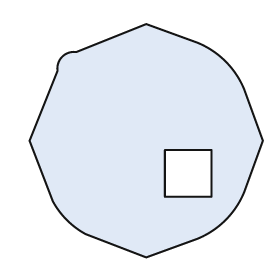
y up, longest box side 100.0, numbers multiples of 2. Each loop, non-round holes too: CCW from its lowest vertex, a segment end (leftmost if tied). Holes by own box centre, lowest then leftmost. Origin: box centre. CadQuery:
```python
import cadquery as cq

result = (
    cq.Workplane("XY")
    .moveTo(0.0, -50.0)
    .lineTo(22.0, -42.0)
    .threePointArc((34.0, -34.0), (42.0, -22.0))
    .lineTo(50.0, 0.0)
    .lineTo(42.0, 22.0)
    .threePointArc((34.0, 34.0), (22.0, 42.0))
    .lineTo(0.0, 50.0)
    .lineTo(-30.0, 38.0)
    .threePointArc((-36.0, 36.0), (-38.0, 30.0))
    .lineTo(-50.0, 0.0)
    .lineTo(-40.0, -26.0)
    .threePointArc((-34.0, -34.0), (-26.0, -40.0))
    .close()
    .moveTo(8.0, -24.0)
    .lineTo(28.0, -24.0)
    .lineTo(28.0, -4.0)
    .lineTo(8.0, -4.0)
    .close()
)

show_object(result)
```